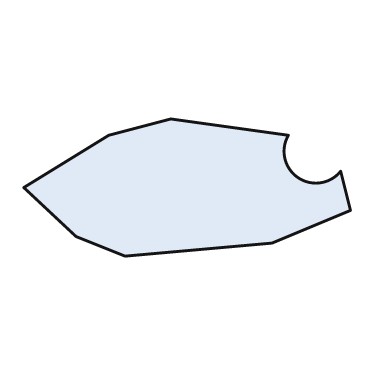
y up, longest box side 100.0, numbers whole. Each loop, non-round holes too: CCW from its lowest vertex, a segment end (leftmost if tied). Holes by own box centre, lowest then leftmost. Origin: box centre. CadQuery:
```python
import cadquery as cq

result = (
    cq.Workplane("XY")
    .moveTo(-19.0, -21.0)
    .lineTo(26.0, -17.0)
    .lineTo(50.0, -7.0)
    .lineTo(47.0, 5.0)
    .threePointArc((34.0, 3.0), (31.0, 16.0))
    .lineTo(-5.0, 21.0)
    .lineTo(-24.0, 16.0)
    .lineTo(-50.0, 0.0)
    .lineTo(-34.0, -15.0)
    .close()
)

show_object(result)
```